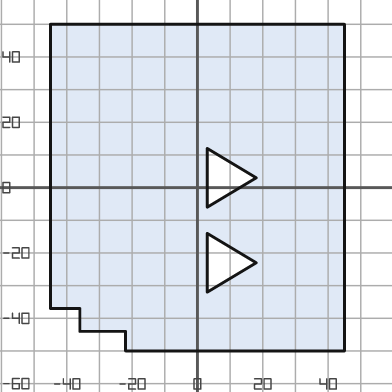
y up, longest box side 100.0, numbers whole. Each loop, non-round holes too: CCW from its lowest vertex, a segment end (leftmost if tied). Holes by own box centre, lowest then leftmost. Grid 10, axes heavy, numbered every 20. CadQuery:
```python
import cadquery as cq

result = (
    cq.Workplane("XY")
    .moveTo(-22.0, -50.0)
    .lineTo(45.0, -50.0)
    .lineTo(45.0, 50.0)
    .lineTo(-45.0, 50.0)
    .lineTo(-45.0, -37.0)
    .lineTo(-36.0, -37.0)
    .lineTo(-36.0, -44.0)
    .lineTo(-22.0, -44.0)
    .close()
    .moveTo(3.0, -32.0)
    .lineTo(18.0, -23.0)
    .lineTo(3.0, -14.0)
    .close()
    .moveTo(3.0, -6.0)
    .lineTo(18.0, 3.0)
    .lineTo(3.0, 12.0)
    .close()
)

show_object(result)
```